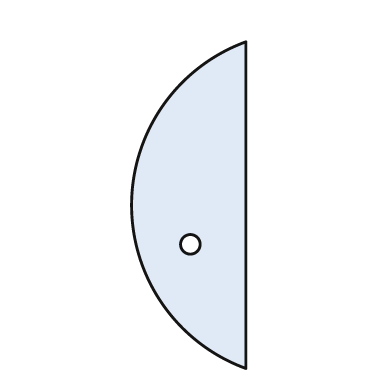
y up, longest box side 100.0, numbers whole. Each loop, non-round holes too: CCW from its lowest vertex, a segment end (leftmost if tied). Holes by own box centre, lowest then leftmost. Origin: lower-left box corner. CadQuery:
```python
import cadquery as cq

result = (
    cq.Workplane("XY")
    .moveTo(35.0, 0.0)
    .lineTo(35.0, 100.0)
    .threePointArc((0.0, 50.0), (35.0, 0.0))
    .close()
    .moveTo(18.0, 38.0)
    .circle(3.0)
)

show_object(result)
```